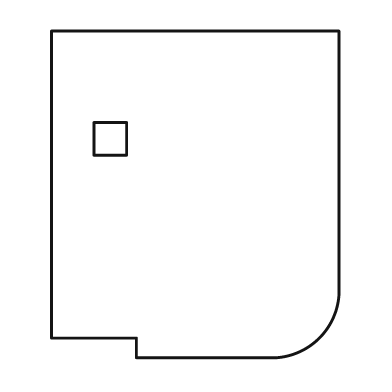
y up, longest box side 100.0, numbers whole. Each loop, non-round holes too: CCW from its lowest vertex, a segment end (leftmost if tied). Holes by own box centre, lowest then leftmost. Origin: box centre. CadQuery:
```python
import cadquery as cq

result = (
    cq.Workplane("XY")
    .moveTo(-18.0, -50.0)
    .lineTo(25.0, -50.0)
    .threePointArc((38.0, -44.0), (44.0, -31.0))
    .lineTo(44.0, 50.0)
    .lineTo(-44.0, 50.0)
    .lineTo(-44.0, -44.0)
    .lineTo(-18.0, -44.0)
    .close()
    .moveTo(-31.0, 12.0)
    .lineTo(-21.0, 12.0)
    .lineTo(-21.0, 22.0)
    .lineTo(-31.0, 22.0)
    .close()
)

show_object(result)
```